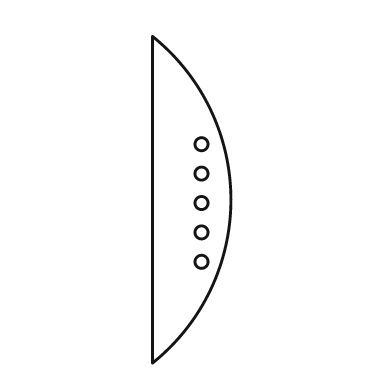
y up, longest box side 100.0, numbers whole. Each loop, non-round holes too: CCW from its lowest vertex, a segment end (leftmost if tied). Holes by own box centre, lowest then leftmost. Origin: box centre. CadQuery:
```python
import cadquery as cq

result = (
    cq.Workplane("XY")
    .moveTo(-12.0, -50.0)
    .threePointArc((12.0, 0.0), (-12.0, 50.0))
    .close()
    .moveTo(3.0, -19.0)
    .circle(2.0)
    .moveTo(3.0, -10.0)
    .circle(2.0)
    .moveTo(3.0, -1.0)
    .circle(2.0)
    .moveTo(3.0, 8.0)
    .circle(2.0)
    .moveTo(3.0, 17.0)
    .circle(2.0)
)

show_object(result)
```